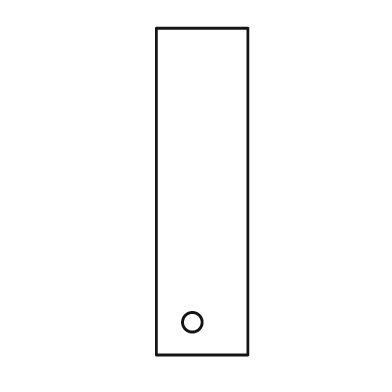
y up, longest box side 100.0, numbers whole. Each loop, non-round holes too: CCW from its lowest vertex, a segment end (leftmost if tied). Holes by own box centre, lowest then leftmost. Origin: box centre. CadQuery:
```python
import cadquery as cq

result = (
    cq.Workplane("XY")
    .moveTo(-14.0, -50.0)
    .lineTo(14.0, -50.0)
    .lineTo(14.0, 50.0)
    .lineTo(-14.0, 50.0)
    .close()
    .moveTo(-3.0, -40.0)
    .circle(3.0)
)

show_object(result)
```